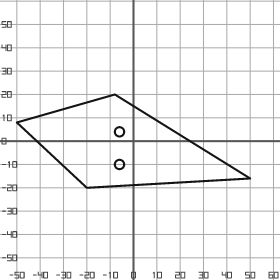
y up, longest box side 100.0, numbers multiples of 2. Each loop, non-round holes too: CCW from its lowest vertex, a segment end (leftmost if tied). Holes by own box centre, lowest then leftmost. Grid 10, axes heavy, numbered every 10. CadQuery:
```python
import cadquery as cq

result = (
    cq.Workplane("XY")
    .moveTo(-20.0, -20.0)
    .lineTo(50.0, -16.0)
    .lineTo(-8.0, 20.0)
    .lineTo(-50.0, 8.0)
    .close()
    .moveTo(-6.0, -10.0)
    .circle(2.0)
    .moveTo(-6.0, 4.0)
    .circle(2.0)
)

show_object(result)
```